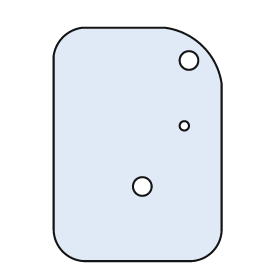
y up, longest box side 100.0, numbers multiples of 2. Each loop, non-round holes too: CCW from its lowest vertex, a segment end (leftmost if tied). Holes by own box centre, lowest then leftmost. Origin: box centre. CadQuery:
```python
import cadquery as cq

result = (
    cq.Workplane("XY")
    .moveTo(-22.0, -50.0)
    .lineTo(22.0, -50.0)
    .threePointArc((32.0, -46.0), (36.0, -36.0))
    .lineTo(36.0, 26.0)
    .threePointArc((28.0, 42.0), (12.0, 50.0))
    .lineTo(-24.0, 50.0)
    .threePointArc((-32.0, 46.0), (-36.0, 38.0))
    .lineTo(-36.0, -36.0)
    .threePointArc((-32.0, -46.0), (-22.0, -50.0))
    .close()
    .moveTo(2.0, -18.0)
    .circle(4.0)
    .moveTo(20.0, 8.0)
    .circle(2.0)
    .moveTo(22.0, 36.0)
    .circle(4.0)
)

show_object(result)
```